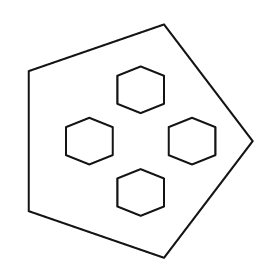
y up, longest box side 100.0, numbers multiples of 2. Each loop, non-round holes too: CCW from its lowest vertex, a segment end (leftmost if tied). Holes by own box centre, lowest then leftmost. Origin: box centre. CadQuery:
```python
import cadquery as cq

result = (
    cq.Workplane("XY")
    .moveTo(10.0, -50.0)
    .lineTo(48.0, 0.0)
    .lineTo(10.0, 50.0)
    .lineTo(-48.0, 30.0)
    .lineTo(-48.0, -30.0)
    .close()
    .moveTo(0.0, -32.0)
    .lineTo(10.0, -28.0)
    .lineTo(10.0, -16.0)
    .lineTo(0.0, -12.0)
    .lineTo(-10.0, -16.0)
    .lineTo(-10.0, -28.0)
    .close()
    .moveTo(-22.0, -10.0)
    .lineTo(-12.0, -6.0)
    .lineTo(-12.0, 6.0)
    .lineTo(-22.0, 10.0)
    .lineTo(-32.0, 6.0)
    .lineTo(-32.0, -6.0)
    .close()
    .moveTo(22.0, -10.0)
    .lineTo(32.0, -6.0)
    .lineTo(32.0, 6.0)
    .lineTo(22.0, 10.0)
    .lineTo(12.0, 6.0)
    .lineTo(12.0, -6.0)
    .close()
    .moveTo(0.0, 12.0)
    .lineTo(10.0, 16.0)
    .lineTo(10.0, 28.0)
    .lineTo(0.0, 32.0)
    .lineTo(-10.0, 28.0)
    .lineTo(-10.0, 16.0)
    .close()
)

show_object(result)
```